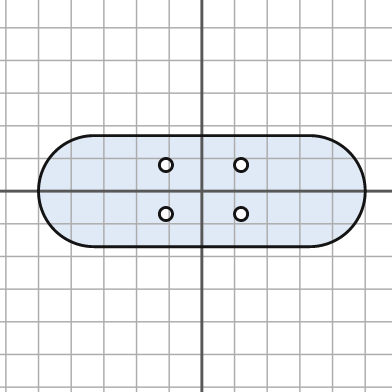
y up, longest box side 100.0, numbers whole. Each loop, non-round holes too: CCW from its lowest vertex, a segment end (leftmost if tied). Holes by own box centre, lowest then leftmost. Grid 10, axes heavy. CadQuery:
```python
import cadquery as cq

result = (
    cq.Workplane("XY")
    .moveTo(-33.0, -17.0)
    .lineTo(33.0, -17.0)
    .threePointArc((50.0, 0.0), (33.0, 17.0))
    .lineTo(-33.0, 17.0)
    .threePointArc((-50.0, 0.0), (-33.0, -17.0))
    .close()
    .moveTo(-11.0, -7.0)
    .circle(2.0)
    .moveTo(12.0, -7.0)
    .circle(2.0)
    .moveTo(-11.0, 8.0)
    .circle(2.0)
    .moveTo(12.0, 8.0)
    .circle(2.0)
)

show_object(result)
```